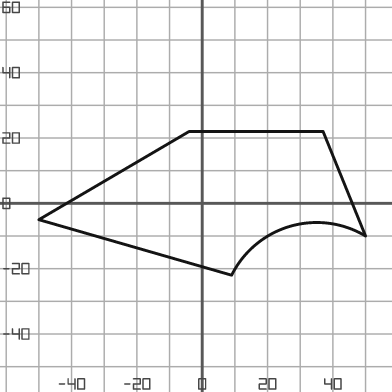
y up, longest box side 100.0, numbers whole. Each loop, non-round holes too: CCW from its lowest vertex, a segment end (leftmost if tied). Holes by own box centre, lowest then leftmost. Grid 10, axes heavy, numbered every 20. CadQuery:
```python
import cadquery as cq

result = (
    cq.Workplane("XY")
    .moveTo(9.0, -22.0)
    .threePointArc((27.0, -7.0), (50.0, -10.0))
    .lineTo(37.0, 22.0)
    .lineTo(-4.0, 22.0)
    .lineTo(-50.0, -5.0)
    .close()
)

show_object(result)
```